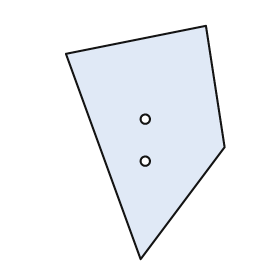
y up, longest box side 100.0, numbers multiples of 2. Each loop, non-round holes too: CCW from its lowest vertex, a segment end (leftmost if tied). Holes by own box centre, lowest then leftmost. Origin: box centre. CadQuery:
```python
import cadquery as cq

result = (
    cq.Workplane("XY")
    .moveTo(-2.0, -50.0)
    .lineTo(34.0, -2.0)
    .lineTo(26.0, 50.0)
    .lineTo(-34.0, 38.0)
    .close()
    .moveTo(0.0, -8.0)
    .circle(2.0)
    .moveTo(0.0, 10.0)
    .circle(2.0)
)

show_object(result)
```